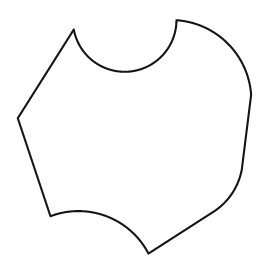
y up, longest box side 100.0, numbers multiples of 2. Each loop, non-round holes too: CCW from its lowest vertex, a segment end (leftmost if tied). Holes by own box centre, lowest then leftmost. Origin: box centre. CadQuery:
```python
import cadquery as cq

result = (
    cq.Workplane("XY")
    .moveTo(6.0, -50.0)
    .lineTo(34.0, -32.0)
    .threePointArc((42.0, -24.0), (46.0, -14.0))
    .lineTo(50.0, 18.0)
    .threePointArc((40.0, 40.0), (18.0, 50.0))
    .threePointArc((-2.0, 28.0), (-26.0, 46.0))
    .lineTo(-50.0, 8.0)
    .lineTo(-36.0, -34.0)
    .threePointArc((-12.0, -34.0), (6.0, -50.0))
    .close()
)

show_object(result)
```